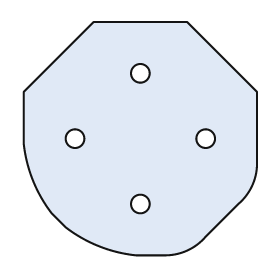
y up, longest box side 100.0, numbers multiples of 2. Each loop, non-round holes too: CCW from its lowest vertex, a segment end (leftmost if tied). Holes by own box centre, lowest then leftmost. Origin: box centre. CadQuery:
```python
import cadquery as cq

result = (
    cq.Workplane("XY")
    .moveTo(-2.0, -50.0)
    .lineTo(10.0, -50.0)
    .threePointArc((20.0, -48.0), (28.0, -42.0))
    .lineTo(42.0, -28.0)
    .threePointArc((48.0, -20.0), (50.0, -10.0))
    .lineTo(50.0, 20.0)
    .lineTo(20.0, 50.0)
    .lineTo(-20.0, 50.0)
    .lineTo(-50.0, 20.0)
    .lineTo(-50.0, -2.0)
    .threePointArc((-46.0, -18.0), (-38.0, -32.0))
    .lineTo(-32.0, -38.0)
    .threePointArc((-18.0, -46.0), (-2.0, -50.0))
    .close()
    .moveTo(0.0, -28.0)
    .circle(4.0)
    .moveTo(-28.0, 0.0)
    .circle(4.0)
    .moveTo(28.0, 0.0)
    .circle(4.0)
    .moveTo(0.0, 28.0)
    .circle(4.0)
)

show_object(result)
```